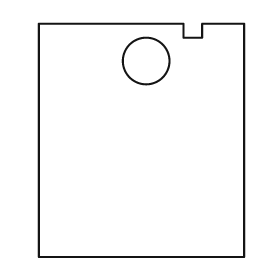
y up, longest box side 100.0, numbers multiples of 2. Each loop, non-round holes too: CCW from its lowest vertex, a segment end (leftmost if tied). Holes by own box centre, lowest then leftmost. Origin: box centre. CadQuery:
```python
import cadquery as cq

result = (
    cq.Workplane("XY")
    .moveTo(-44.0, -50.0)
    .lineTo(44.0, -50.0)
    .lineTo(44.0, 50.0)
    .lineTo(26.0, 50.0)
    .lineTo(26.0, 44.0)
    .lineTo(18.0, 44.0)
    .lineTo(18.0, 50.0)
    .lineTo(-44.0, 50.0)
    .close()
    .moveTo(2.0, 34.0)
    .circle(10.0)
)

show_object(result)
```